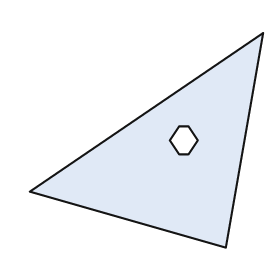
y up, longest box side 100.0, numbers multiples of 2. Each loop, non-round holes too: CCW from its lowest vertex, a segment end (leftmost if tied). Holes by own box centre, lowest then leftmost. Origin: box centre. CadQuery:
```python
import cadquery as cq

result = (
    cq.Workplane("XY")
    .moveTo(34.0, -46.0)
    .lineTo(50.0, 46.0)
    .lineTo(-50.0, -22.0)
    .close()
    .moveTo(14.0, -6.0)
    .lineTo(18.0, -6.0)
    .lineTo(22.0, 0.0)
    .lineTo(18.0, 6.0)
    .lineTo(14.0, 6.0)
    .lineTo(10.0, 0.0)
    .close()
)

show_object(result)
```